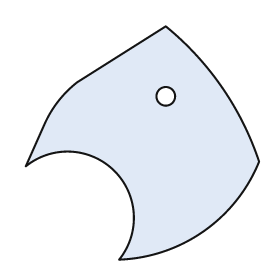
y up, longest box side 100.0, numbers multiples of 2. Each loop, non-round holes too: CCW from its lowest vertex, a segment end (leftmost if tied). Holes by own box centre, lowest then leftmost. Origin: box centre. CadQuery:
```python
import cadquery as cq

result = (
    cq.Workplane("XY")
    .moveTo(-10.0, -50.0)
    .threePointArc((26.0, -38.0), (50.0, -8.0))
    .threePointArc((34.0, 24.0), (10.0, 50.0))
    .lineTo(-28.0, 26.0)
    .threePointArc((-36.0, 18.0), (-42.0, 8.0))
    .lineTo(-50.0, -10.0)
    .threePointArc((-12.0, -12.0), (-10.0, -50.0))
    .close()
    .moveTo(10.0, 20.0)
    .circle(4.0)
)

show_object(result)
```